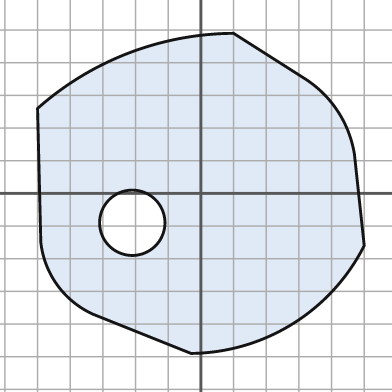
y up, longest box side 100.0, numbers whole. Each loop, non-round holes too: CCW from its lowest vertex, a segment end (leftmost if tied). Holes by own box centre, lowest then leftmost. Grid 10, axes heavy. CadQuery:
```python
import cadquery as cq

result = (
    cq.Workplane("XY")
    .moveTo(-3.0, -49.0)
    .threePointArc((28.0, -40.0), (50.0, -16.0))
    .lineTo(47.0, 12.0)
    .threePointArc((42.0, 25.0), (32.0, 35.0))
    .lineTo(10.0, 49.0)
    .threePointArc((-22.0, 43.0), (-50.0, 26.0))
    .lineTo(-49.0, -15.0)
    .threePointArc((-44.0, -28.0), (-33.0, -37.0))
    .close()
    .moveTo(-21.0, -9.0)
    .circle(10.0)
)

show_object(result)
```